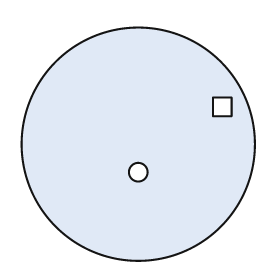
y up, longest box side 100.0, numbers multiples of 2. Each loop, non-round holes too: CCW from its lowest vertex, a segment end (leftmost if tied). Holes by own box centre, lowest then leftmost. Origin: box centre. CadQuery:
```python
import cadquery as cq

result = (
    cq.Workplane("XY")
    .moveTo(0.0, 0.0)
    .circle(50.0)
    .moveTo(0.0, -12.0)
    .circle(4.0)
    .moveTo(32.0, 12.0)
    .lineTo(40.0, 12.0)
    .lineTo(40.0, 20.0)
    .lineTo(32.0, 20.0)
    .close()
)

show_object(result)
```